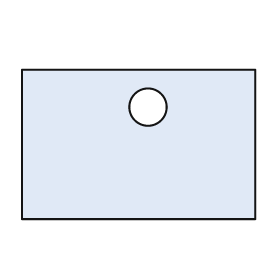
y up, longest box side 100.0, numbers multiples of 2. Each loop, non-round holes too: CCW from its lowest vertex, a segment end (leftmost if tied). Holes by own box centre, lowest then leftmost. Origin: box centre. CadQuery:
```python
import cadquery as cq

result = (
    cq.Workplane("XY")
    .moveTo(-50.0, -32.0)
    .lineTo(50.0, -32.0)
    .lineTo(50.0, 32.0)
    .lineTo(-50.0, 32.0)
    .close()
    .moveTo(4.0, 16.0)
    .circle(8.0)
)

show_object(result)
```